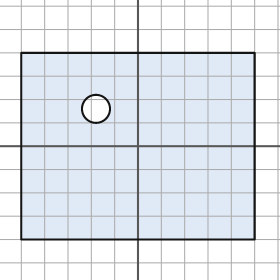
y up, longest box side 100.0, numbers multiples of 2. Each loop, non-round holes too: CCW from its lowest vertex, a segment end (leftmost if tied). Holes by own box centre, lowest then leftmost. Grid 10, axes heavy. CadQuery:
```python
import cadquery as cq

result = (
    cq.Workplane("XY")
    .moveTo(-50.0, -40.0)
    .lineTo(50.0, -40.0)
    .lineTo(50.0, 40.0)
    .lineTo(-50.0, 40.0)
    .close()
    .moveTo(-18.0, 16.0)
    .circle(6.0)
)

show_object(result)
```